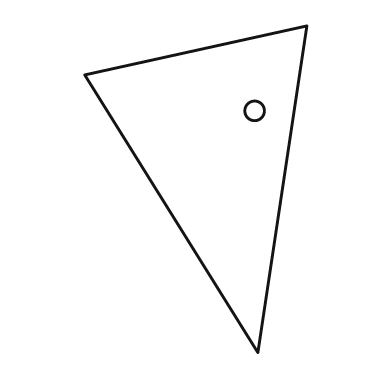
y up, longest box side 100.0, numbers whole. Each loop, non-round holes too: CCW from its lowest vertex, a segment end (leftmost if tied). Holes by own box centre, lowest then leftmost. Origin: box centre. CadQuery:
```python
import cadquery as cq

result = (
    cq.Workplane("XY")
    .moveTo(19.0, -50.0)
    .lineTo(34.0, 50.0)
    .lineTo(-34.0, 35.0)
    .close()
    .moveTo(18.0, 24.0)
    .circle(3.0)
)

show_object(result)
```